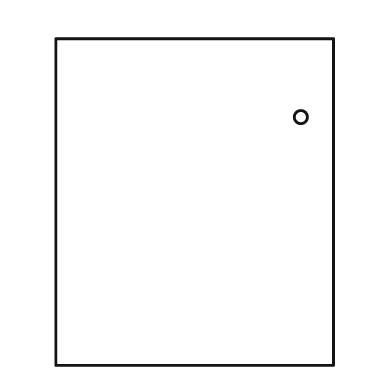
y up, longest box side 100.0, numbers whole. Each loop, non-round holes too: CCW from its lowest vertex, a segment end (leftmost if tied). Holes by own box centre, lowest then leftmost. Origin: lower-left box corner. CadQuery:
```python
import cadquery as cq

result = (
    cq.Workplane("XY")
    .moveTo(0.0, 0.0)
    .lineTo(85.0, 0.0)
    .lineTo(85.0, 100.0)
    .lineTo(0.0, 100.0)
    .close()
    .moveTo(75.0, 76.0)
    .circle(2.0)
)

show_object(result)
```